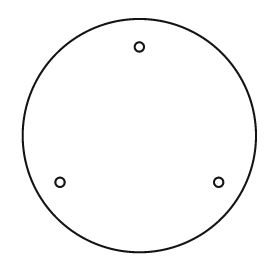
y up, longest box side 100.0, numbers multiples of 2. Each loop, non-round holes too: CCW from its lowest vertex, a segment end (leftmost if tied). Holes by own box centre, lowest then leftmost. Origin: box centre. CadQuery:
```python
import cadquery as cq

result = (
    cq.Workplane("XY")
    .moveTo(0.0, 0.0)
    .circle(50.0)
    .moveTo(-34.0, -20.0)
    .circle(2.0)
    .moveTo(34.0, -20.0)
    .circle(2.0)
    .moveTo(0.0, 38.0)
    .circle(2.0)
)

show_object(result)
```